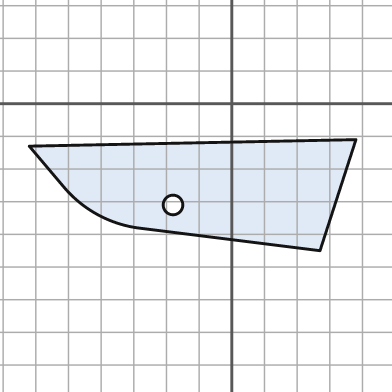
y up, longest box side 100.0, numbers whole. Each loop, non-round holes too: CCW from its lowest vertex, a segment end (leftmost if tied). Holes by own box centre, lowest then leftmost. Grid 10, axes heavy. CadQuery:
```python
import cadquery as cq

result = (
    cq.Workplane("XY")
    .moveTo(27.0, -45.0)
    .lineTo(38.0, -11.0)
    .lineTo(-62.0, -13.0)
    .lineTo(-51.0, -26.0)
    .threePointArc((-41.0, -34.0), (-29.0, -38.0))
    .close()
    .moveTo(-18.0, -31.0)
    .circle(3.0)
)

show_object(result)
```